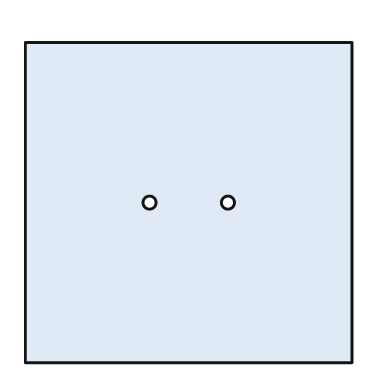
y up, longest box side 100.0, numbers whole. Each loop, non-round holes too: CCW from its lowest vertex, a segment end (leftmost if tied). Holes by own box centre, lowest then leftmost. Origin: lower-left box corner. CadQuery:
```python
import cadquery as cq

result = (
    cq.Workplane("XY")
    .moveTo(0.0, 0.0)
    .lineTo(100.0, 0.0)
    .lineTo(100.0, 98.0)
    .lineTo(0.0, 98.0)
    .close()
    .moveTo(38.0, 49.0)
    .circle(2.0)
    .moveTo(62.0, 49.0)
    .circle(2.0)
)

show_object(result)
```